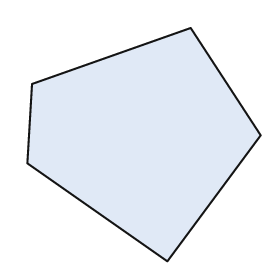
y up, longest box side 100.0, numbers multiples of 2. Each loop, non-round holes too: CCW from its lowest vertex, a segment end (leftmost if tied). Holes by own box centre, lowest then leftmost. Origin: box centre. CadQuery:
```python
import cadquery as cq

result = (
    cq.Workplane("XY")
    .moveTo(10.0, -50.0)
    .lineTo(50.0, 4.0)
    .lineTo(20.0, 50.0)
    .lineTo(-48.0, 26.0)
    .lineTo(-50.0, -8.0)
    .close()
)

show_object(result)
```